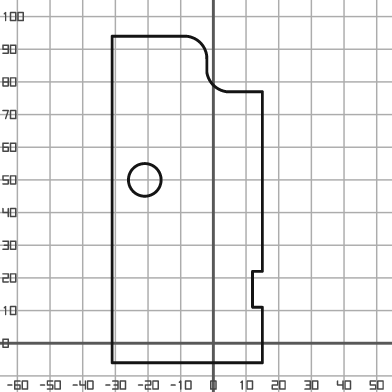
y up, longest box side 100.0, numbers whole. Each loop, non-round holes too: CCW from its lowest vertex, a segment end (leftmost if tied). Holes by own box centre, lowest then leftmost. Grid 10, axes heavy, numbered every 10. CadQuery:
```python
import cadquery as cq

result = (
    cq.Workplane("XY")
    .moveTo(-31.0, -6.0)
    .lineTo(15.0, -6.0)
    .lineTo(15.0, 11.0)
    .lineTo(12.0, 11.0)
    .lineTo(12.0, 22.0)
    .lineTo(15.0, 22.0)
    .lineTo(15.0, 77.0)
    .lineTo(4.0, 77.0)
    .threePointArc((0.0, 79.0), (-2.0, 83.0))
    .lineTo(-2.0, 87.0)
    .threePointArc((-4.0, 92.0), (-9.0, 94.0))
    .lineTo(-31.0, 94.0)
    .close()
    .moveTo(-21.0, 50.0)
    .circle(5.0)
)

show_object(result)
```